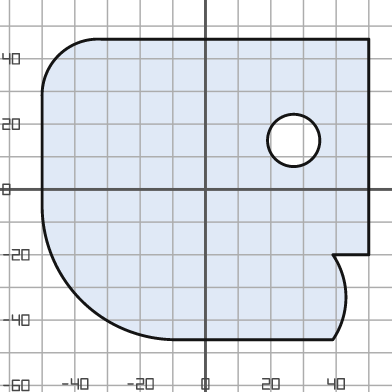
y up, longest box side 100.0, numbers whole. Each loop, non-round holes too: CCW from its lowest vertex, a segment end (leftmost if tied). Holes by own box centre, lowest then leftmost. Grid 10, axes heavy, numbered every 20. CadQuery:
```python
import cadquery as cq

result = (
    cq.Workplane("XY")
    .moveTo(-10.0, -46.0)
    .lineTo(39.0, -46.0)
    .threePointArc((43.0, -33.0), (39.0, -20.0))
    .lineTo(50.0, -20.0)
    .lineTo(50.0, 46.0)
    .lineTo(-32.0, 46.0)
    .threePointArc((-45.0, 41.0), (-50.0, 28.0))
    .lineTo(-50.0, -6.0)
    .threePointArc((-38.0, -34.0), (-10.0, -46.0))
    .close()
    .moveTo(27.0, 15.0)
    .circle(8.0)
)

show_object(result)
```